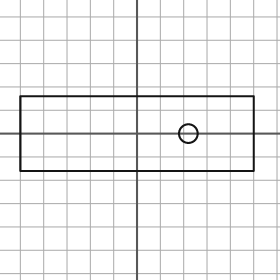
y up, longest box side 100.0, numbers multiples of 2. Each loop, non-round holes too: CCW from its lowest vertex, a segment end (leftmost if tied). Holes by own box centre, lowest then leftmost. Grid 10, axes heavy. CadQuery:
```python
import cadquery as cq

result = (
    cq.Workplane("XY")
    .moveTo(-50.0, -16.0)
    .lineTo(50.0, -16.0)
    .lineTo(50.0, 16.0)
    .lineTo(-50.0, 16.0)
    .close()
    .moveTo(22.0, 0.0)
    .circle(4.0)
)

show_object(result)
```